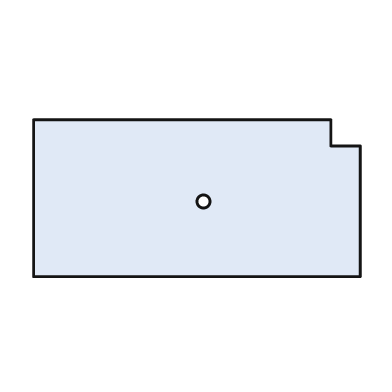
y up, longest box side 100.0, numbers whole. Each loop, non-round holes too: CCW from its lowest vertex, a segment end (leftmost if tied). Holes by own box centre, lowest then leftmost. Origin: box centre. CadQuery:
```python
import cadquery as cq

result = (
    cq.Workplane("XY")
    .moveTo(-50.0, -24.0)
    .lineTo(50.0, -24.0)
    .lineTo(50.0, 16.0)
    .lineTo(41.0, 16.0)
    .lineTo(41.0, 24.0)
    .lineTo(-50.0, 24.0)
    .close()
    .moveTo(2.0, -1.0)
    .circle(2.0)
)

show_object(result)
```